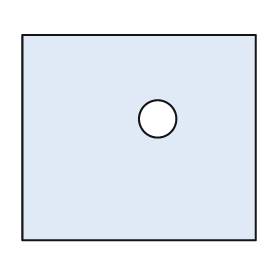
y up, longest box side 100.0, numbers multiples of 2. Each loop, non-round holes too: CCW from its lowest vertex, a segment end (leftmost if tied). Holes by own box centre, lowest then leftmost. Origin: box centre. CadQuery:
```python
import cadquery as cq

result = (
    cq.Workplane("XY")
    .moveTo(-50.0, -44.0)
    .lineTo(50.0, -44.0)
    .lineTo(50.0, 44.0)
    .lineTo(-50.0, 44.0)
    .close()
    .moveTo(8.0, 8.0)
    .circle(8.0)
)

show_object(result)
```